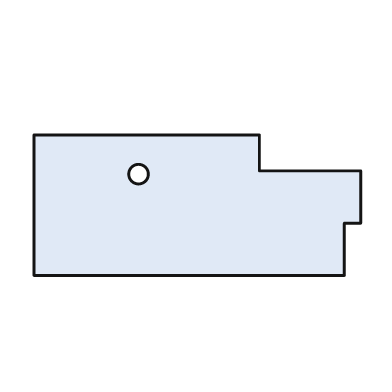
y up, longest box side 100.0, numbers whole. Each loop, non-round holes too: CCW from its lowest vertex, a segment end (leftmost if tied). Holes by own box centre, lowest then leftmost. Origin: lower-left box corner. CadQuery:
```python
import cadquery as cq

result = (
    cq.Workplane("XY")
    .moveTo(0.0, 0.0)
    .lineTo(95.0, 0.0)
    .lineTo(95.0, 16.0)
    .lineTo(100.0, 16.0)
    .lineTo(100.0, 32.0)
    .lineTo(69.0, 32.0)
    .lineTo(69.0, 43.0)
    .lineTo(0.0, 43.0)
    .close()
    .moveTo(32.0, 31.0)
    .circle(3.0)
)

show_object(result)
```